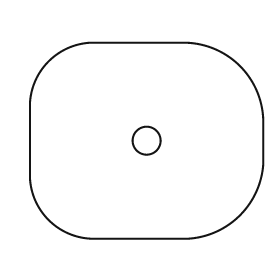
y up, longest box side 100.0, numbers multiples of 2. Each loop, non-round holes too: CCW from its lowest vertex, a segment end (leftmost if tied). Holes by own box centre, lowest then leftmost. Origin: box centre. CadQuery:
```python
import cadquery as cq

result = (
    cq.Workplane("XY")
    .moveTo(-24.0, -42.0)
    .lineTo(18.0, -42.0)
    .threePointArc((40.0, -32.0), (50.0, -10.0))
    .lineTo(50.0, 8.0)
    .threePointArc((40.0, 32.0), (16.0, 42.0))
    .lineTo(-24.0, 42.0)
    .threePointArc((-42.0, 34.0), (-50.0, 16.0))
    .lineTo(-50.0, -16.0)
    .threePointArc((-42.0, -34.0), (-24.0, -42.0))
    .close()
    .moveTo(0.0, 0.0)
    .circle(6.0)
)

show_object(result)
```